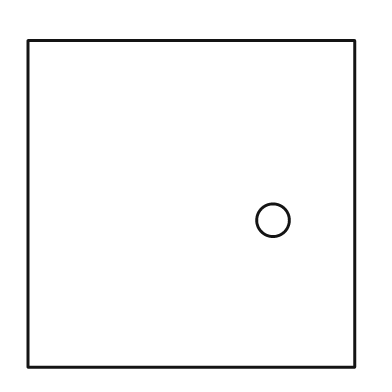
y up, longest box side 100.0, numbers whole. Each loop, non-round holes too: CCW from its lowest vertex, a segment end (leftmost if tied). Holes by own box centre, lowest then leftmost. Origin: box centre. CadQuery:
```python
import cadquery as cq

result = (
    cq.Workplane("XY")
    .moveTo(-50.0, -50.0)
    .lineTo(50.0, -50.0)
    .lineTo(50.0, 50.0)
    .lineTo(-50.0, 50.0)
    .close()
    .moveTo(25.0, -5.0)
    .circle(5.0)
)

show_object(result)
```